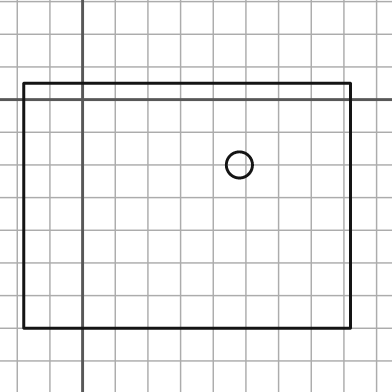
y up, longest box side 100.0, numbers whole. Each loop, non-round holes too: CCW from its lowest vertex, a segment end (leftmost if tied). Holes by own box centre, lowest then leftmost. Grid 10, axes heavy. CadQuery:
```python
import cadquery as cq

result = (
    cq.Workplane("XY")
    .moveTo(-18.0, -70.0)
    .lineTo(82.0, -70.0)
    .lineTo(82.0, 5.0)
    .lineTo(-18.0, 5.0)
    .close()
    .moveTo(48.0, -20.0)
    .circle(4.0)
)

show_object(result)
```